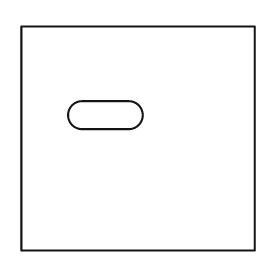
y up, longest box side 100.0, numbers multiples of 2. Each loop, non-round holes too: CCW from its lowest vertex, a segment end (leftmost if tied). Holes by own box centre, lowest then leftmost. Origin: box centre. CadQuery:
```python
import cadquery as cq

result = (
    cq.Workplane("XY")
    .moveTo(-50.0, -48.0)
    .lineTo(50.0, -48.0)
    .lineTo(50.0, 48.0)
    .lineTo(-50.0, 48.0)
    .close()
    .moveTo(-24.0, 4.0)
    .lineTo(-4.0, 4.0)
    .threePointArc((2.0, 10.0), (-4.0, 16.0))
    .lineTo(-24.0, 16.0)
    .threePointArc((-30.0, 10.0), (-24.0, 4.0))
    .close()
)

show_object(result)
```